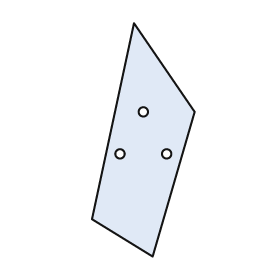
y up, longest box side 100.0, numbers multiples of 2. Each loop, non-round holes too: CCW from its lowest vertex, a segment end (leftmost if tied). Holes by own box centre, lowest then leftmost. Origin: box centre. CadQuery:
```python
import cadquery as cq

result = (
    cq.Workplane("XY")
    .moveTo(4.0, -50.0)
    .lineTo(22.0, 12.0)
    .lineTo(-4.0, 50.0)
    .lineTo(-22.0, -34.0)
    .close()
    .moveTo(-10.0, -6.0)
    .circle(2.0)
    .moveTo(10.0, -6.0)
    .circle(2.0)
    .moveTo(0.0, 12.0)
    .circle(2.0)
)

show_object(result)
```